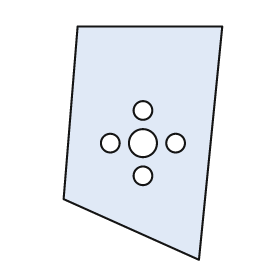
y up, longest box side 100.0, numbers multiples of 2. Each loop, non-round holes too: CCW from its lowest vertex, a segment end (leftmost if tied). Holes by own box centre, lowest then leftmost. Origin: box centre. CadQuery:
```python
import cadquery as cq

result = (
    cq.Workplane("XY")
    .moveTo(24.0, -50.0)
    .lineTo(34.0, 50.0)
    .lineTo(-28.0, 50.0)
    .lineTo(-34.0, -24.0)
    .close()
    .moveTo(0.0, -14.0)
    .circle(4.0)
    .moveTo(-14.0, 0.0)
    .circle(4.0)
    .moveTo(0.0, 0.0)
    .circle(6.0)
    .moveTo(14.0, 0.0)
    .circle(4.0)
    .moveTo(0.0, 14.0)
    .circle(4.0)
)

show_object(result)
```